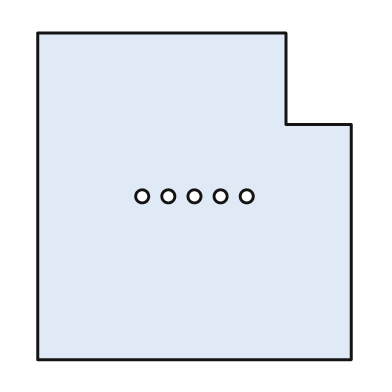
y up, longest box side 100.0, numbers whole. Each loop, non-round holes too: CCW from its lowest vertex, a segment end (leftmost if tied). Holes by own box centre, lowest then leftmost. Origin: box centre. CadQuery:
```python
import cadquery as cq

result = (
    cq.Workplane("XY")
    .moveTo(-48.0, -50.0)
    .lineTo(48.0, -50.0)
    .lineTo(48.0, 22.0)
    .lineTo(28.0, 22.0)
    .lineTo(28.0, 50.0)
    .lineTo(-48.0, 50.0)
    .close()
    .moveTo(-16.0, 0.0)
    .circle(2.0)
    .moveTo(-8.0, 0.0)
    .circle(2.0)
    .moveTo(0.0, 0.0)
    .circle(2.0)
    .moveTo(8.0, 0.0)
    .circle(2.0)
    .moveTo(16.0, 0.0)
    .circle(2.0)
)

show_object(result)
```